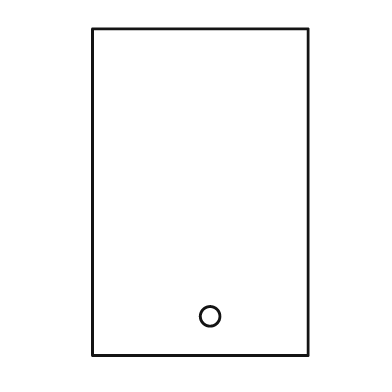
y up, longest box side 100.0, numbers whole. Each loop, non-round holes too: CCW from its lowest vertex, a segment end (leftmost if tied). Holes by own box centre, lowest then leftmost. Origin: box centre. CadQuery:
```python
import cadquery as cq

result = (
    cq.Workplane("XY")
    .moveTo(-33.0, -50.0)
    .lineTo(33.0, -50.0)
    .lineTo(33.0, 50.0)
    .lineTo(-33.0, 50.0)
    .close()
    .moveTo(3.0, -38.0)
    .circle(3.0)
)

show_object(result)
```